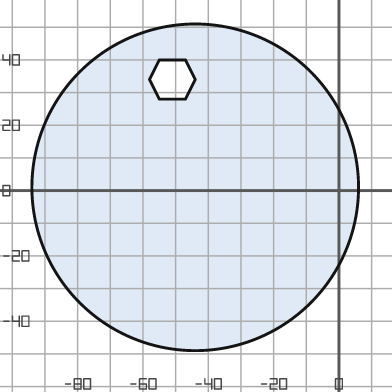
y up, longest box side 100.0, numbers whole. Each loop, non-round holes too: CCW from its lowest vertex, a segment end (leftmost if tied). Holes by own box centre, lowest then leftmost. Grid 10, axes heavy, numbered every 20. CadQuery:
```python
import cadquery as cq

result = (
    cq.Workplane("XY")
    .moveTo(-44.0, 1.0)
    .circle(50.0)
    .moveTo(-55.0, 28.0)
    .lineTo(-47.0, 28.0)
    .lineTo(-44.0, 34.0)
    .lineTo(-47.0, 40.0)
    .lineTo(-55.0, 40.0)
    .lineTo(-58.0, 34.0)
    .close()
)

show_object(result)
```